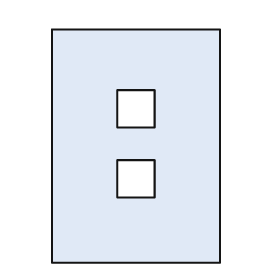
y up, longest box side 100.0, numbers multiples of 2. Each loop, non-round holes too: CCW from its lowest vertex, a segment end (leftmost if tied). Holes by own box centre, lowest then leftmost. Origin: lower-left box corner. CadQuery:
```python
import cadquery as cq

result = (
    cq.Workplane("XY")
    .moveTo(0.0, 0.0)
    .lineTo(72.0, 0.0)
    .lineTo(72.0, 100.0)
    .lineTo(0.0, 100.0)
    .close()
    .moveTo(28.0, 28.0)
    .lineTo(44.0, 28.0)
    .lineTo(44.0, 44.0)
    .lineTo(28.0, 44.0)
    .close()
    .moveTo(28.0, 58.0)
    .lineTo(44.0, 58.0)
    .lineTo(44.0, 74.0)
    .lineTo(28.0, 74.0)
    .close()
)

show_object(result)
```